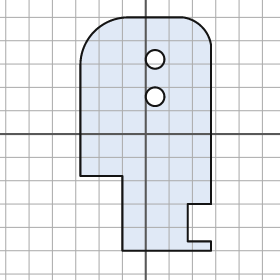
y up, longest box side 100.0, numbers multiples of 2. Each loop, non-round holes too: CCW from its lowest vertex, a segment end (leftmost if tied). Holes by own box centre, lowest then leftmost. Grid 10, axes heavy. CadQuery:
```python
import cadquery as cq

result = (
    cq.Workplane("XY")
    .moveTo(-10.0, -50.0)
    .lineTo(28.0, -50.0)
    .lineTo(28.0, -46.0)
    .lineTo(18.0, -46.0)
    .lineTo(18.0, -30.0)
    .lineTo(28.0, -30.0)
    .lineTo(28.0, 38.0)
    .threePointArc((24.0, 46.0), (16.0, 50.0))
    .lineTo(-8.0, 50.0)
    .threePointArc((-22.0, 44.0), (-28.0, 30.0))
    .lineTo(-28.0, -18.0)
    .lineTo(-10.0, -18.0)
    .close()
    .moveTo(4.0, 16.0)
    .circle(4.0)
    .moveTo(4.0, 32.0)
    .circle(4.0)
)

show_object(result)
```